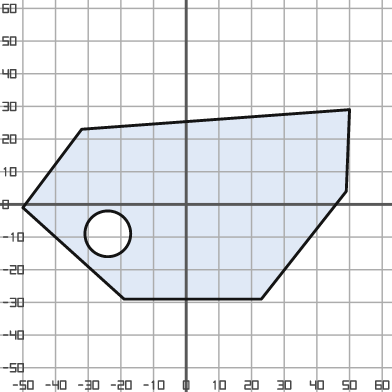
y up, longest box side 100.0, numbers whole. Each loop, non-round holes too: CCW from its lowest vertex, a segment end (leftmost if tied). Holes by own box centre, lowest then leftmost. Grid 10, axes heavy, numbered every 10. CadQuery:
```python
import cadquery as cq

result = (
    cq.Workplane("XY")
    .moveTo(-19.0, -29.0)
    .lineTo(23.0, -29.0)
    .lineTo(49.0, 4.0)
    .lineTo(50.0, 29.0)
    .lineTo(-32.0, 23.0)
    .lineTo(-50.0, -1.0)
    .close()
    .moveTo(-24.0, -9.0)
    .circle(7.0)
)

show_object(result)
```